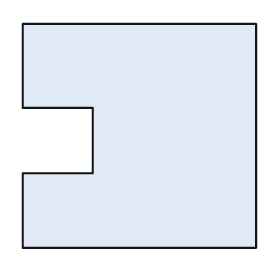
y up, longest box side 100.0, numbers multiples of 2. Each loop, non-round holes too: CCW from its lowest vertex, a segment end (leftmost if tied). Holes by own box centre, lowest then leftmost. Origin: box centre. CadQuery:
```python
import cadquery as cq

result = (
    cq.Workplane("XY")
    .moveTo(-50.0, -48.0)
    .lineTo(50.0, -48.0)
    .lineTo(50.0, 48.0)
    .lineTo(-50.0, 48.0)
    .lineTo(-50.0, 12.0)
    .lineTo(-20.0, 12.0)
    .lineTo(-20.0, -16.0)
    .lineTo(-50.0, -16.0)
    .close()
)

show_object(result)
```